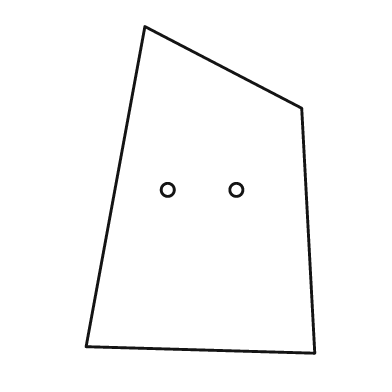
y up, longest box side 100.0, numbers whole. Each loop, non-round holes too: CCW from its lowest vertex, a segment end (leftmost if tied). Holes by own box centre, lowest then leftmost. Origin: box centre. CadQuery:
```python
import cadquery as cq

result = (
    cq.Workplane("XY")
    .moveTo(35.0, -50.0)
    .lineTo(31.0, 25.0)
    .lineTo(-17.0, 50.0)
    .lineTo(-35.0, -48.0)
    .close()
    .moveTo(-10.0, 0.0)
    .circle(2.0)
    .moveTo(11.0, 0.0)
    .circle(2.0)
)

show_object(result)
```